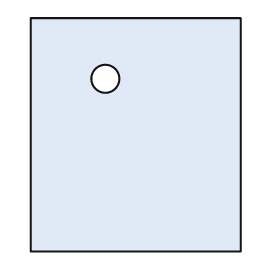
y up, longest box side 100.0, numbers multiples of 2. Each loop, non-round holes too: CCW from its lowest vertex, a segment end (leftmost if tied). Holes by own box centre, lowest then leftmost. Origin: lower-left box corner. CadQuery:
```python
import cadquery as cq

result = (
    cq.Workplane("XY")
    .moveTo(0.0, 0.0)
    .lineTo(90.0, 0.0)
    .lineTo(90.0, 100.0)
    .lineTo(0.0, 100.0)
    .close()
    .moveTo(32.0, 74.0)
    .circle(6.0)
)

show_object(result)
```